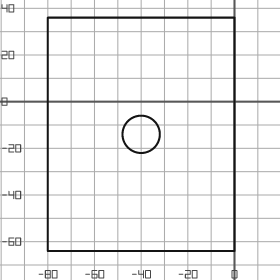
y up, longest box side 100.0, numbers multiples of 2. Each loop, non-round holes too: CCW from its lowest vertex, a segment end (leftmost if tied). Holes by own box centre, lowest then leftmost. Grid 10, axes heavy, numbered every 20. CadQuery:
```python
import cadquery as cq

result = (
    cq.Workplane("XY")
    .moveTo(-80.0, -64.0)
    .lineTo(0.0, -64.0)
    .lineTo(0.0, 36.0)
    .lineTo(-80.0, 36.0)
    .close()
    .moveTo(-40.0, -14.0)
    .circle(8.0)
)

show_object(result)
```